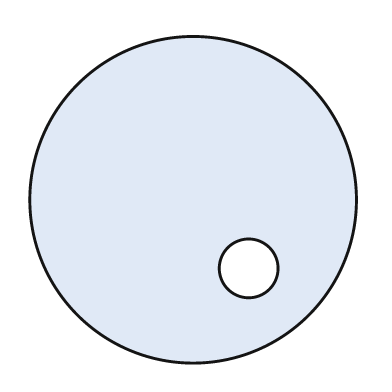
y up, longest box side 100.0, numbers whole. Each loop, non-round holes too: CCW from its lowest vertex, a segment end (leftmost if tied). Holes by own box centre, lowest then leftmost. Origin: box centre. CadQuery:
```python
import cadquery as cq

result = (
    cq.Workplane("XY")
    .moveTo(0.0, 0.0)
    .circle(50.0)
    .moveTo(17.0, -21.0)
    .circle(9.0)
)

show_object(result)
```